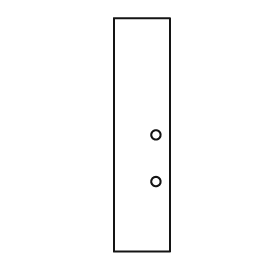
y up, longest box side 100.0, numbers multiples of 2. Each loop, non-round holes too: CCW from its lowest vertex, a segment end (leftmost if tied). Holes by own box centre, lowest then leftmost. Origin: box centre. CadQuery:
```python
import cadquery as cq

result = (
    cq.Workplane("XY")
    .moveTo(-12.0, -50.0)
    .lineTo(12.0, -50.0)
    .lineTo(12.0, 50.0)
    .lineTo(-12.0, 50.0)
    .close()
    .moveTo(6.0, -20.0)
    .circle(2.0)
    .moveTo(6.0, 0.0)
    .circle(2.0)
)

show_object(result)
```